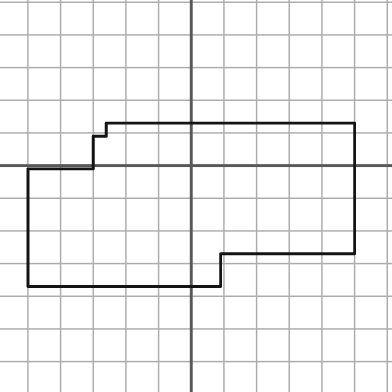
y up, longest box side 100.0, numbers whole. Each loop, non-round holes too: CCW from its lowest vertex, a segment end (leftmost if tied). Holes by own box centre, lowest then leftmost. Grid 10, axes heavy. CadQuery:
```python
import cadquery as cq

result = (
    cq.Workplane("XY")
    .moveTo(-50.0, -37.0)
    .lineTo(9.0, -37.0)
    .lineTo(9.0, -27.0)
    .lineTo(50.0, -27.0)
    .lineTo(50.0, 13.0)
    .lineTo(-26.0, 13.0)
    .lineTo(-26.0, 9.0)
    .lineTo(-30.0, 9.0)
    .lineTo(-30.0, -1.0)
    .lineTo(-50.0, -1.0)
    .close()
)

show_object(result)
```